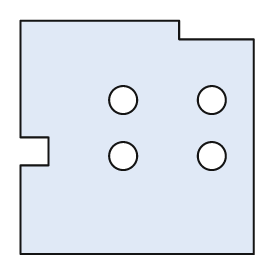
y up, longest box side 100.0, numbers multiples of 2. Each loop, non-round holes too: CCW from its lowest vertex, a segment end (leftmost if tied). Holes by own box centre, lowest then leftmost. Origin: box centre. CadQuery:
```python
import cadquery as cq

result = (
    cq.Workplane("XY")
    .moveTo(-50.0, -50.0)
    .lineTo(50.0, -50.0)
    .lineTo(50.0, 42.0)
    .lineTo(18.0, 42.0)
    .lineTo(18.0, 50.0)
    .lineTo(-50.0, 50.0)
    .lineTo(-50.0, 0.0)
    .lineTo(-38.0, 0.0)
    .lineTo(-38.0, -12.0)
    .lineTo(-50.0, -12.0)
    .close()
    .moveTo(-6.0, -8.0)
    .circle(6.0)
    .moveTo(32.0, -8.0)
    .circle(6.0)
    .moveTo(-6.0, 16.0)
    .circle(6.0)
    .moveTo(32.0, 16.0)
    .circle(6.0)
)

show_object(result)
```